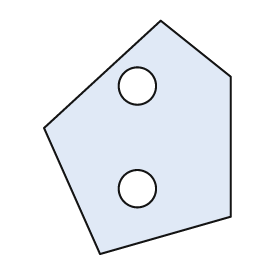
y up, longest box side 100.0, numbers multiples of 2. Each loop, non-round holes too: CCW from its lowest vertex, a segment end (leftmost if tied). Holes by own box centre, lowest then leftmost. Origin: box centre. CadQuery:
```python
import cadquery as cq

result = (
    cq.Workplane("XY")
    .moveTo(-16.0, -50.0)
    .lineTo(40.0, -34.0)
    .lineTo(40.0, 26.0)
    .lineTo(10.0, 50.0)
    .lineTo(-40.0, 4.0)
    .close()
    .moveTo(0.0, -22.0)
    .circle(8.0)
    .moveTo(0.0, 22.0)
    .circle(8.0)
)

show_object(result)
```